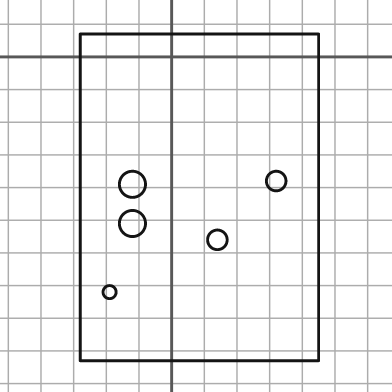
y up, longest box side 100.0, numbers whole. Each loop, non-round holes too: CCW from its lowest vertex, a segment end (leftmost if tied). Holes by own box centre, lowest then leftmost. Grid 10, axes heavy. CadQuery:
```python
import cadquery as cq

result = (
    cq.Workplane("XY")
    .moveTo(-28.0, -93.0)
    .lineTo(45.0, -93.0)
    .lineTo(45.0, 7.0)
    .lineTo(-28.0, 7.0)
    .close()
    .moveTo(-19.0, -72.0)
    .circle(2.0)
    .moveTo(14.0, -56.0)
    .circle(3.0)
    .moveTo(-12.0, -51.0)
    .circle(4.0)
    .moveTo(-12.0, -39.0)
    .circle(4.0)
    .moveTo(32.0, -38.0)
    .circle(3.0)
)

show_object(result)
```